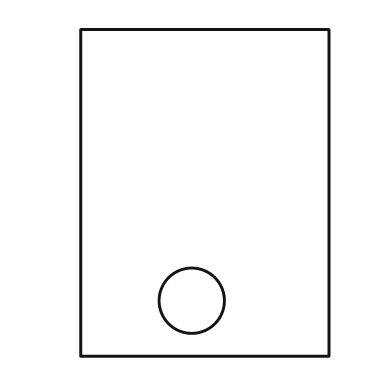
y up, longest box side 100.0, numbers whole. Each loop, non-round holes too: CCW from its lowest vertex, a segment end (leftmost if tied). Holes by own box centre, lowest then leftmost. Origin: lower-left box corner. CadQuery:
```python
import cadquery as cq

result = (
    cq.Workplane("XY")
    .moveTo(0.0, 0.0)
    .lineTo(76.0, 0.0)
    .lineTo(76.0, 100.0)
    .lineTo(0.0, 100.0)
    .close()
    .moveTo(34.0, 17.0)
    .circle(10.0)
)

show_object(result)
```